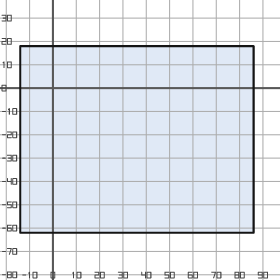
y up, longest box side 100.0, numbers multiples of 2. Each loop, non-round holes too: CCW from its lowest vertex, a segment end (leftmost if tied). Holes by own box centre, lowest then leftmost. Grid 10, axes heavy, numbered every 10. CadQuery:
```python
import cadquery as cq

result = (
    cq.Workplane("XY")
    .moveTo(-14.0, -62.0)
    .lineTo(86.0, -62.0)
    .lineTo(86.0, 18.0)
    .lineTo(-14.0, 18.0)
    .close()
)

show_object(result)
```